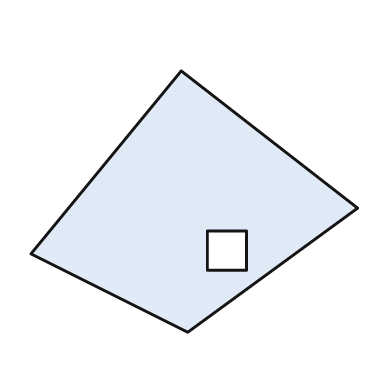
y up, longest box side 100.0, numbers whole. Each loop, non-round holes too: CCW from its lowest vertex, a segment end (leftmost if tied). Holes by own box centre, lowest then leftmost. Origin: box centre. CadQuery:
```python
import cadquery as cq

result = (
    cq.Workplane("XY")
    .moveTo(-2.0, -40.0)
    .lineTo(50.0, -2.0)
    .lineTo(-4.0, 40.0)
    .lineTo(-50.0, -16.0)
    .close()
    .moveTo(4.0, -21.0)
    .lineTo(16.0, -21.0)
    .lineTo(16.0, -9.0)
    .lineTo(4.0, -9.0)
    .close()
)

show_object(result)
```